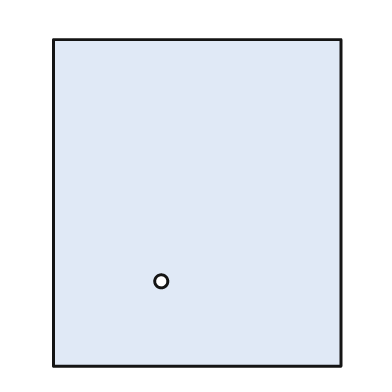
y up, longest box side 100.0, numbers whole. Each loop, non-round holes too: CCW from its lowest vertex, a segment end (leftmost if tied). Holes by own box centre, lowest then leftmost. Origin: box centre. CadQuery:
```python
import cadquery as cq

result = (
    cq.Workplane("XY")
    .moveTo(-44.0, -50.0)
    .lineTo(44.0, -50.0)
    .lineTo(44.0, 50.0)
    .lineTo(-44.0, 50.0)
    .close()
    .moveTo(-11.0, -24.0)
    .circle(2.0)
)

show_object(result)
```